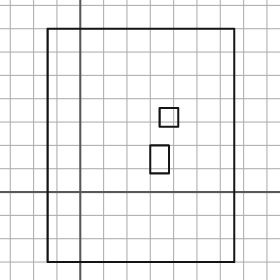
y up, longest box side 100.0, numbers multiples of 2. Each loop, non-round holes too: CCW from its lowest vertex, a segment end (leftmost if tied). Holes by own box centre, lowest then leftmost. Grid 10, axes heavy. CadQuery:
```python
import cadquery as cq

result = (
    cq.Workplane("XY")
    .moveTo(-14.0, -30.0)
    .lineTo(66.0, -30.0)
    .lineTo(66.0, 70.0)
    .lineTo(-14.0, 70.0)
    .close()
    .moveTo(30.0, 8.0)
    .lineTo(38.0, 8.0)
    .lineTo(38.0, 20.0)
    .lineTo(30.0, 20.0)
    .close()
    .moveTo(34.0, 28.0)
    .lineTo(42.0, 28.0)
    .lineTo(42.0, 36.0)
    .lineTo(34.0, 36.0)
    .close()
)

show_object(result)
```